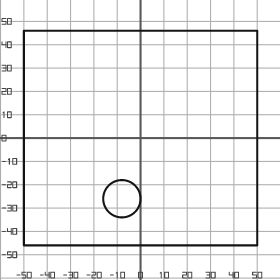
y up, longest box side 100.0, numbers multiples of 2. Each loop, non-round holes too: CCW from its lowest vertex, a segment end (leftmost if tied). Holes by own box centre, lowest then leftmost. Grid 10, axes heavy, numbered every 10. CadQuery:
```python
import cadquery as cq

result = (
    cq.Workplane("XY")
    .moveTo(-50.0, -46.0)
    .lineTo(50.0, -46.0)
    .lineTo(50.0, 46.0)
    .lineTo(-50.0, 46.0)
    .close()
    .moveTo(-8.0, -26.0)
    .circle(8.0)
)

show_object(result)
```